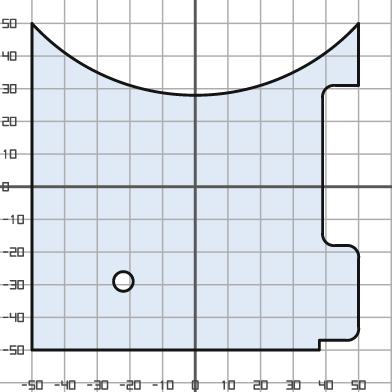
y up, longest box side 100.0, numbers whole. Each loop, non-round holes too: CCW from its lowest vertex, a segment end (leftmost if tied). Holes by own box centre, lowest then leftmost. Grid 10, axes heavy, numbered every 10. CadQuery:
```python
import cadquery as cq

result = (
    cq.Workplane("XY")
    .moveTo(-50.0, -50.0)
    .lineTo(38.0, -50.0)
    .lineTo(38.0, -47.0)
    .lineTo(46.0, -47.0)
    .threePointArc((49.0, -46.0), (50.0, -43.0))
    .lineTo(50.0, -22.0)
    .threePointArc((49.0, -19.0), (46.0, -18.0))
    .lineTo(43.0, -18.0)
    .threePointArc((40.0, -17.0), (39.0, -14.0))
    .lineTo(39.0, 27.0)
    .threePointArc((40.0, 30.0), (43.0, 31.0))
    .lineTo(50.0, 31.0)
    .lineTo(50.0, 50.0)
    .threePointArc((0.0, 28.0), (-50.0, 50.0))
    .close()
    .moveTo(-22.0, -29.0)
    .circle(3.0)
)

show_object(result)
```